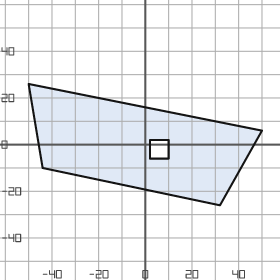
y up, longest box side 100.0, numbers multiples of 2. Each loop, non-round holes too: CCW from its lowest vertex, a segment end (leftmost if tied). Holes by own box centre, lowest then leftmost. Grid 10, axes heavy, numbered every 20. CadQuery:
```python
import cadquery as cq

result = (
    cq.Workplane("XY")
    .moveTo(32.0, -26.0)
    .lineTo(50.0, 6.0)
    .lineTo(-50.0, 26.0)
    .lineTo(-44.0, -10.0)
    .close()
    .moveTo(2.0, -6.0)
    .lineTo(10.0, -6.0)
    .lineTo(10.0, 2.0)
    .lineTo(2.0, 2.0)
    .close()
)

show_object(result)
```